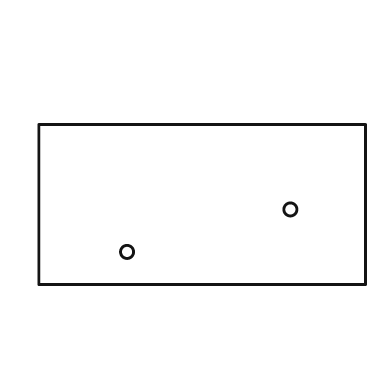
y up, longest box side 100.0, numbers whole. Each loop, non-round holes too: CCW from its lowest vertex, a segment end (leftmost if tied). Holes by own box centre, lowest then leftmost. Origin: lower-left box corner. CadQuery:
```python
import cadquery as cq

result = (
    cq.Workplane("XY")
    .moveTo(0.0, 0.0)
    .lineTo(100.0, 0.0)
    .lineTo(100.0, 49.0)
    .lineTo(0.0, 49.0)
    .close()
    .moveTo(27.0, 10.0)
    .circle(2.0)
    .moveTo(77.0, 23.0)
    .circle(2.0)
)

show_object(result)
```